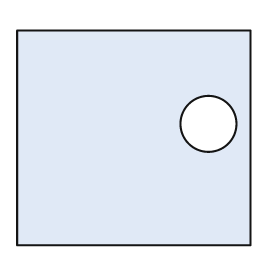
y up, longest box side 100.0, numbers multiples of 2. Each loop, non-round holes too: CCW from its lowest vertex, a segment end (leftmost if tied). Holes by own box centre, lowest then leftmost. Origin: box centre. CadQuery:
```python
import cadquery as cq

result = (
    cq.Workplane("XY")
    .moveTo(-50.0, -46.0)
    .lineTo(50.0, -46.0)
    .lineTo(50.0, 46.0)
    .lineTo(-50.0, 46.0)
    .close()
    .moveTo(32.0, 6.0)
    .circle(12.0)
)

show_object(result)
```